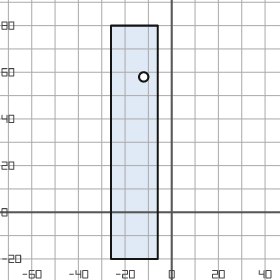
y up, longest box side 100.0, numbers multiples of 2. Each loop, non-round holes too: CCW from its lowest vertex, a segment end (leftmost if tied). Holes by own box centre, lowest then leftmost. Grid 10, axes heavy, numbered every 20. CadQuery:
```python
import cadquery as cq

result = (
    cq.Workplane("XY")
    .moveTo(-26.0, -20.0)
    .lineTo(-6.0, -20.0)
    .lineTo(-6.0, 80.0)
    .lineTo(-26.0, 80.0)
    .close()
    .moveTo(-12.0, 58.0)
    .circle(2.0)
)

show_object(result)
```